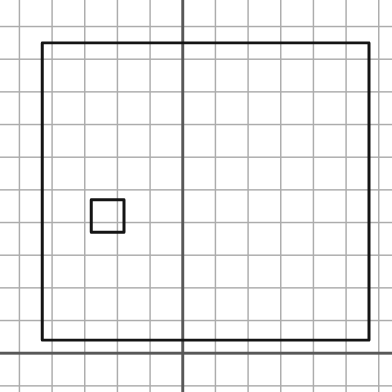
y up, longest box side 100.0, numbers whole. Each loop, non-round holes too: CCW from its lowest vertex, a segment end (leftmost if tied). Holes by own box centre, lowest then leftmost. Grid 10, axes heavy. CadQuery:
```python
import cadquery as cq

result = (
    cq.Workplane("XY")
    .moveTo(-43.0, 4.0)
    .lineTo(57.0, 4.0)
    .lineTo(57.0, 95.0)
    .lineTo(-43.0, 95.0)
    .close()
    .moveTo(-28.0, 37.0)
    .lineTo(-18.0, 37.0)
    .lineTo(-18.0, 47.0)
    .lineTo(-28.0, 47.0)
    .close()
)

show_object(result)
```